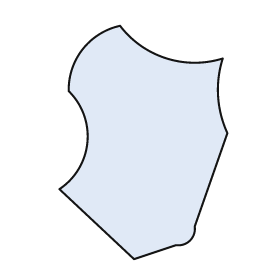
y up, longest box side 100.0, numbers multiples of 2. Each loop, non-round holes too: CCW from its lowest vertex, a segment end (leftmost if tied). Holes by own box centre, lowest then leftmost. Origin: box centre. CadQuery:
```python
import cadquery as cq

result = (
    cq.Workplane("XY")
    .moveTo(-4.0, -50.0)
    .lineTo(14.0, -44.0)
    .threePointArc((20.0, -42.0), (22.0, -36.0))
    .lineTo(36.0, 4.0)
    .threePointArc((32.0, 20.0), (34.0, 36.0))
    .threePointArc((10.0, 36.0), (-10.0, 50.0))
    .threePointArc((-26.0, 40.0), (-32.0, 22.0))
    .threePointArc((-24.0, 0.0), (-36.0, -20.0))
    .close()
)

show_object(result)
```